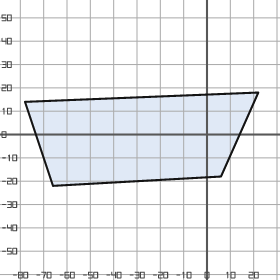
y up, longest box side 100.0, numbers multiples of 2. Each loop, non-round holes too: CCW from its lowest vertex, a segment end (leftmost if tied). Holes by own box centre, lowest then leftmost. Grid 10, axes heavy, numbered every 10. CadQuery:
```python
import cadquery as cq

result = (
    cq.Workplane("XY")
    .moveTo(-66.0, -22.0)
    .lineTo(6.0, -18.0)
    .lineTo(22.0, 18.0)
    .lineTo(-78.0, 14.0)
    .close()
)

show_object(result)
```